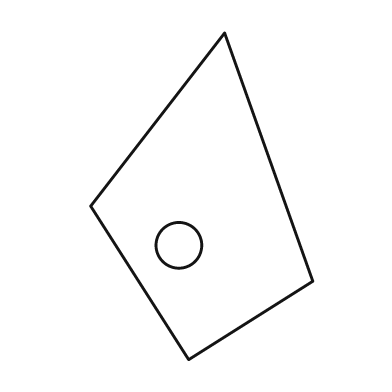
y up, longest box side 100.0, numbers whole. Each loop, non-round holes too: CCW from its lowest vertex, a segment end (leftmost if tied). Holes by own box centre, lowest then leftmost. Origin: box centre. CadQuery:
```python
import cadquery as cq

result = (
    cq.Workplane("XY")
    .moveTo(-4.0, -50.0)
    .lineTo(34.0, -26.0)
    .lineTo(7.0, 50.0)
    .lineTo(-34.0, -3.0)
    .close()
    .moveTo(-7.0, -15.0)
    .circle(7.0)
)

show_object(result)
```